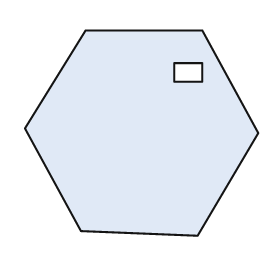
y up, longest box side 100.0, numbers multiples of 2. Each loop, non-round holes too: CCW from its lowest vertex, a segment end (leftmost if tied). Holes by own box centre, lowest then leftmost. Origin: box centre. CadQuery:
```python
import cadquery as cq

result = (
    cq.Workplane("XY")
    .moveTo(24.0, -44.0)
    .lineTo(50.0, 0.0)
    .lineTo(26.0, 44.0)
    .lineTo(-24.0, 44.0)
    .lineTo(-50.0, 2.0)
    .lineTo(-26.0, -42.0)
    .close()
    .moveTo(14.0, 22.0)
    .lineTo(26.0, 22.0)
    .lineTo(26.0, 30.0)
    .lineTo(14.0, 30.0)
    .close()
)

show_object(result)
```